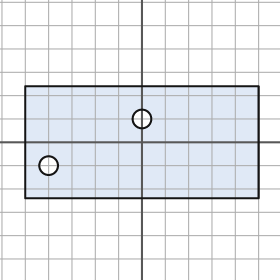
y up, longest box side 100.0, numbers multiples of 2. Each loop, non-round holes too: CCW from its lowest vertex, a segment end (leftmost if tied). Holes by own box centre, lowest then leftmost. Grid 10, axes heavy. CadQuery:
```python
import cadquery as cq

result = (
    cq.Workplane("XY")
    .moveTo(-50.0, -24.0)
    .lineTo(50.0, -24.0)
    .lineTo(50.0, 24.0)
    .lineTo(-50.0, 24.0)
    .close()
    .moveTo(-40.0, -10.0)
    .circle(4.0)
    .moveTo(0.0, 10.0)
    .circle(4.0)
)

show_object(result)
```